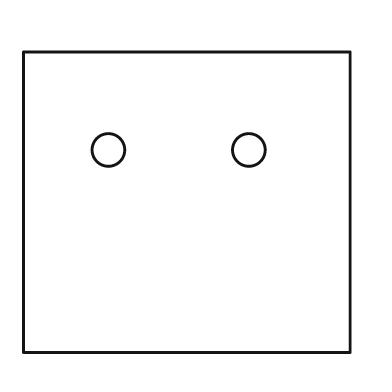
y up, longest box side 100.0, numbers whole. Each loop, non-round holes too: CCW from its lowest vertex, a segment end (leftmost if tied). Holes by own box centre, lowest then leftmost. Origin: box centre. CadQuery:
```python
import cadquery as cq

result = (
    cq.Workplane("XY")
    .moveTo(-50.0, -46.0)
    .lineTo(50.0, -46.0)
    .lineTo(50.0, 46.0)
    .lineTo(-50.0, 46.0)
    .close()
    .moveTo(-24.0, 16.0)
    .circle(5.0)
    .moveTo(19.0, 16.0)
    .circle(5.0)
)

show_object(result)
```